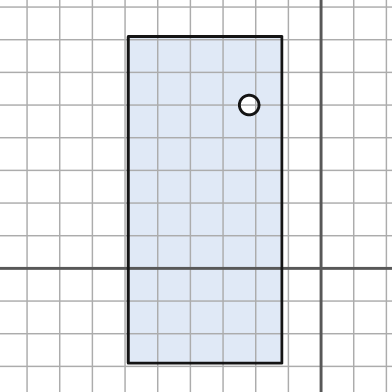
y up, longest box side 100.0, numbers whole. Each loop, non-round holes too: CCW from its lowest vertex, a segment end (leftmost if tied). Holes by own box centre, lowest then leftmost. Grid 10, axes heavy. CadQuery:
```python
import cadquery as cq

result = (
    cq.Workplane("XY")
    .moveTo(-59.0, -29.0)
    .lineTo(-12.0, -29.0)
    .lineTo(-12.0, 71.0)
    .lineTo(-59.0, 71.0)
    .close()
    .moveTo(-22.0, 50.0)
    .circle(3.0)
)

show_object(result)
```